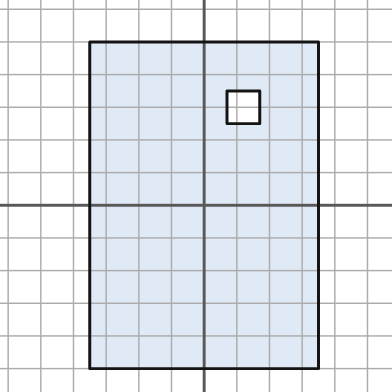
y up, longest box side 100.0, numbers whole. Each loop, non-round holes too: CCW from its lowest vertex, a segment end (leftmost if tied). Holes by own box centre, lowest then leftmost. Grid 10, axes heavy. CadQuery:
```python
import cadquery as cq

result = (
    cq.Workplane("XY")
    .moveTo(-35.0, -50.0)
    .lineTo(35.0, -50.0)
    .lineTo(35.0, 50.0)
    .lineTo(-35.0, 50.0)
    .close()
    .moveTo(7.0, 25.0)
    .lineTo(17.0, 25.0)
    .lineTo(17.0, 35.0)
    .lineTo(7.0, 35.0)
    .close()
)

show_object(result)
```